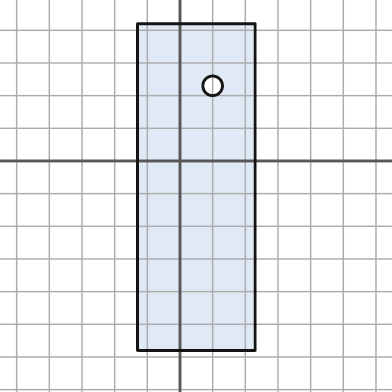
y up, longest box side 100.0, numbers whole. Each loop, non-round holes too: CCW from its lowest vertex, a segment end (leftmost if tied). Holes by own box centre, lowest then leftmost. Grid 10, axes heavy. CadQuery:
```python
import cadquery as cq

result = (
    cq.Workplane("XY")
    .moveTo(-13.0, -58.0)
    .lineTo(23.0, -58.0)
    .lineTo(23.0, 42.0)
    .lineTo(-13.0, 42.0)
    .close()
    .moveTo(10.0, 23.0)
    .circle(3.0)
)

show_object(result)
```